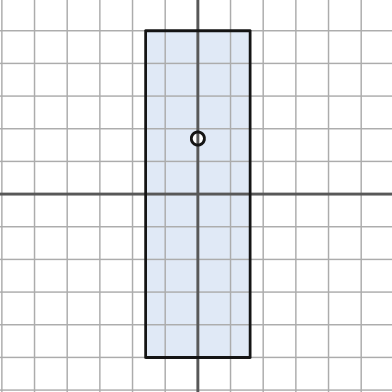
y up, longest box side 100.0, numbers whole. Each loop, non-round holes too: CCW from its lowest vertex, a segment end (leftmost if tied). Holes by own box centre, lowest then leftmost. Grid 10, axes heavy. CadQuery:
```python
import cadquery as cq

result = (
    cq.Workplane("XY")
    .moveTo(-16.0, -50.0)
    .lineTo(16.0, -50.0)
    .lineTo(16.0, 50.0)
    .lineTo(-16.0, 50.0)
    .close()
    .moveTo(0.0, 17.0)
    .circle(2.0)
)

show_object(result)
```